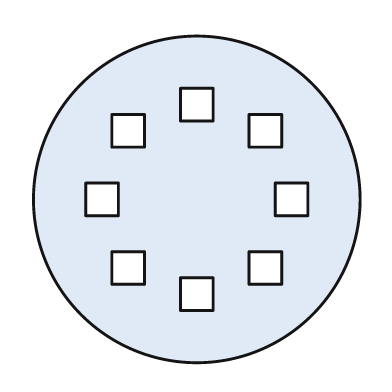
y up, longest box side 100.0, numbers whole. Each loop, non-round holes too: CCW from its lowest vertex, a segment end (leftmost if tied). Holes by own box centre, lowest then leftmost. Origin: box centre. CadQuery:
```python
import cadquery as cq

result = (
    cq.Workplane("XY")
    .moveTo(0.0, 0.0)
    .circle(50.0)
    .moveTo(-5.0, -34.0)
    .lineTo(5.0, -34.0)
    .lineTo(5.0, -24.0)
    .lineTo(-5.0, -24.0)
    .close()
    .moveTo(-26.0, -26.0)
    .lineTo(-16.0, -26.0)
    .lineTo(-16.0, -16.0)
    .lineTo(-26.0, -16.0)
    .close()
    .moveTo(16.0, -26.0)
    .lineTo(26.0, -26.0)
    .lineTo(26.0, -16.0)
    .lineTo(16.0, -16.0)
    .close()
    .moveTo(-34.0, -5.0)
    .lineTo(-24.0, -5.0)
    .lineTo(-24.0, 5.0)
    .lineTo(-34.0, 5.0)
    .close()
    .moveTo(24.0, -5.0)
    .lineTo(34.0, -5.0)
    .lineTo(34.0, 5.0)
    .lineTo(24.0, 5.0)
    .close()
    .moveTo(-26.0, 16.0)
    .lineTo(-16.0, 16.0)
    .lineTo(-16.0, 26.0)
    .lineTo(-26.0, 26.0)
    .close()
    .moveTo(16.0, 16.0)
    .lineTo(26.0, 16.0)
    .lineTo(26.0, 26.0)
    .lineTo(16.0, 26.0)
    .close()
    .moveTo(-5.0, 24.0)
    .lineTo(5.0, 24.0)
    .lineTo(5.0, 34.0)
    .lineTo(-5.0, 34.0)
    .close()
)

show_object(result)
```